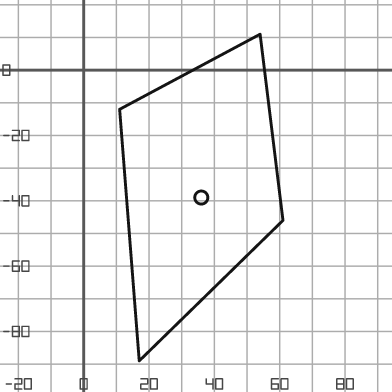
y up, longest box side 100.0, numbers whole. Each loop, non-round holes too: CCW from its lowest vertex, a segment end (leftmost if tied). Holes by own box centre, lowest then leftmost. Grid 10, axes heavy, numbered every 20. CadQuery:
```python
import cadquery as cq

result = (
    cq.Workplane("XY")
    .moveTo(17.0, -89.0)
    .lineTo(61.0, -46.0)
    .lineTo(54.0, 11.0)
    .lineTo(11.0, -12.0)
    .close()
    .moveTo(36.0, -39.0)
    .circle(2.0)
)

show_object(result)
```